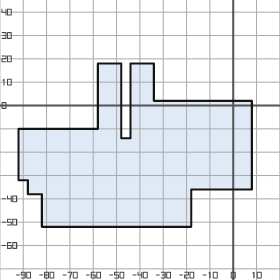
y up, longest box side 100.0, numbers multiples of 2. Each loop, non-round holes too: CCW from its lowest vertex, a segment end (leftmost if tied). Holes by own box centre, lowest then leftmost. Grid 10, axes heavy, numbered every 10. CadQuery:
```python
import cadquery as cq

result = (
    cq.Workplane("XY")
    .moveTo(-82.0, -52.0)
    .lineTo(-18.0, -52.0)
    .lineTo(-18.0, -36.0)
    .lineTo(8.0, -36.0)
    .lineTo(8.0, 2.0)
    .lineTo(-34.0, 2.0)
    .lineTo(-34.0, 18.0)
    .lineTo(-44.0, 18.0)
    .lineTo(-44.0, -14.0)
    .lineTo(-48.0, -14.0)
    .lineTo(-48.0, 18.0)
    .lineTo(-58.0, 18.0)
    .lineTo(-58.0, -10.0)
    .lineTo(-92.0, -10.0)
    .lineTo(-92.0, -32.0)
    .lineTo(-88.0, -32.0)
    .lineTo(-88.0, -38.0)
    .lineTo(-82.0, -38.0)
    .close()
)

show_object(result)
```